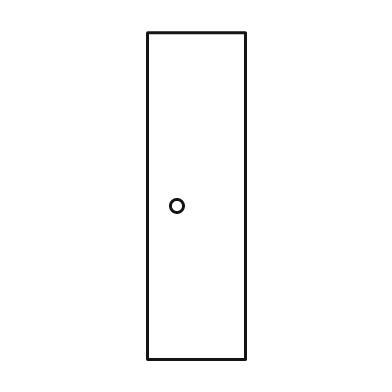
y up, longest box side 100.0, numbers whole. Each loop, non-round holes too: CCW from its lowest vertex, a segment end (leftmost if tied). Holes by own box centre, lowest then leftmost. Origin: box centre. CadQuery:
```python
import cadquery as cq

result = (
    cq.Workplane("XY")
    .moveTo(-15.0, -50.0)
    .lineTo(15.0, -50.0)
    .lineTo(15.0, 50.0)
    .lineTo(-15.0, 50.0)
    .close()
    .moveTo(-6.0, -3.0)
    .circle(2.0)
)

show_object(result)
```